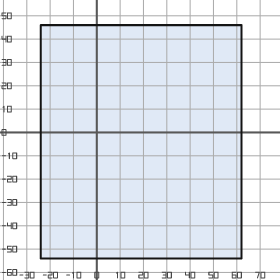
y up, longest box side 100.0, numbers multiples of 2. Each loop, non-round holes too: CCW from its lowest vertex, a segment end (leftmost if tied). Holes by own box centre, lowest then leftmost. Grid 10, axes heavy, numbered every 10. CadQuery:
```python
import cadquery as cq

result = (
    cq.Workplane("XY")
    .moveTo(-24.0, -54.0)
    .lineTo(62.0, -54.0)
    .lineTo(62.0, 46.0)
    .lineTo(-24.0, 46.0)
    .close()
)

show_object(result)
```